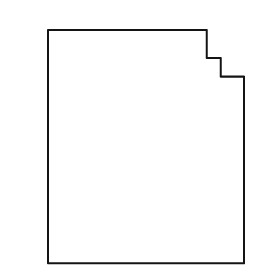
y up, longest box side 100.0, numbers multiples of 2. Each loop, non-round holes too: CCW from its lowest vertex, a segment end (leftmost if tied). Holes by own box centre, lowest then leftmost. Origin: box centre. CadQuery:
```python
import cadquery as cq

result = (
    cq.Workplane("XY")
    .moveTo(-42.0, -50.0)
    .lineTo(42.0, -50.0)
    .lineTo(42.0, 30.0)
    .lineTo(32.0, 30.0)
    .lineTo(32.0, 38.0)
    .lineTo(26.0, 38.0)
    .lineTo(26.0, 50.0)
    .lineTo(-42.0, 50.0)
    .close()
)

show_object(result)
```